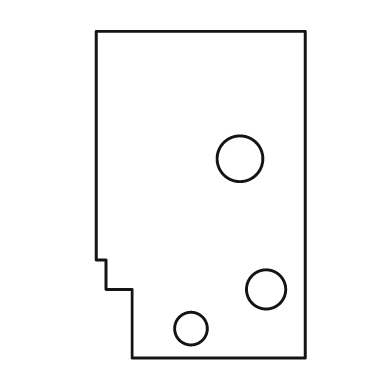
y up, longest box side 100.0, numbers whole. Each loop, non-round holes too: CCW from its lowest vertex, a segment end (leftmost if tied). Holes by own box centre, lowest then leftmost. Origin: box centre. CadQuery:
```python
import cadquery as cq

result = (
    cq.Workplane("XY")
    .moveTo(-21.0, -50.0)
    .lineTo(32.0, -50.0)
    .lineTo(32.0, 50.0)
    .lineTo(-32.0, 50.0)
    .lineTo(-32.0, -20.0)
    .lineTo(-29.0, -20.0)
    .lineTo(-29.0, -29.0)
    .lineTo(-21.0, -29.0)
    .close()
    .moveTo(-3.0, -41.0)
    .circle(5.0)
    .moveTo(20.0, -29.0)
    .circle(6.0)
    .moveTo(12.0, 11.0)
    .circle(7.0)
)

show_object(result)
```